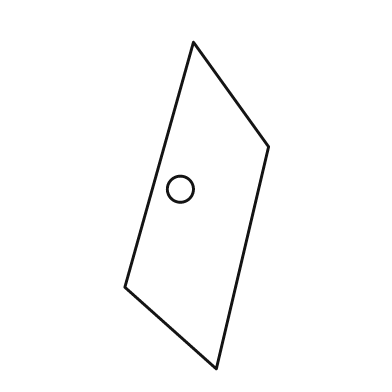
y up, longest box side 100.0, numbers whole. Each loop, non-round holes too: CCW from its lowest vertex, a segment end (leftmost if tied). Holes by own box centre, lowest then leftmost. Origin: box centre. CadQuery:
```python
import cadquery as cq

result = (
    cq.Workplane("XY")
    .moveTo(6.0, -50.0)
    .lineTo(22.0, 18.0)
    .lineTo(-1.0, 50.0)
    .lineTo(-22.0, -25.0)
    .close()
    .moveTo(-5.0, 5.0)
    .circle(4.0)
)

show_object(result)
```